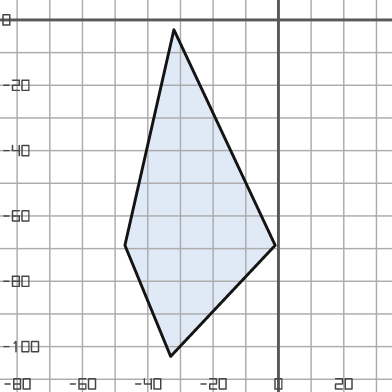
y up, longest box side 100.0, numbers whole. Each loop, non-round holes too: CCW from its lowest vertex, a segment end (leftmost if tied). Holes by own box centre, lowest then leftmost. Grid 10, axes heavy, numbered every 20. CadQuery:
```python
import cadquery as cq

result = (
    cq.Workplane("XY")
    .moveTo(-33.0, -103.0)
    .lineTo(-1.0, -69.0)
    .lineTo(-32.0, -3.0)
    .lineTo(-47.0, -69.0)
    .close()
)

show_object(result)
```